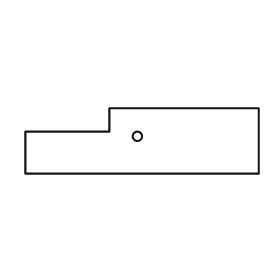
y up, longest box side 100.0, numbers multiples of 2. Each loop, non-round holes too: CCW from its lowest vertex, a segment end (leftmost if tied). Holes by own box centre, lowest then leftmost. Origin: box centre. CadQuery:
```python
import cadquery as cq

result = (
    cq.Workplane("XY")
    .moveTo(-50.0, -14.0)
    .lineTo(50.0, -14.0)
    .lineTo(50.0, 14.0)
    .lineTo(-14.0, 14.0)
    .lineTo(-14.0, 4.0)
    .lineTo(-50.0, 4.0)
    .close()
    .moveTo(-2.0, 2.0)
    .circle(2.0)
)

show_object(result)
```